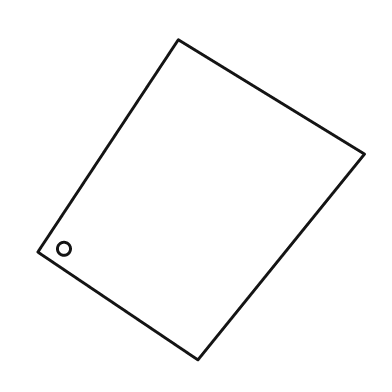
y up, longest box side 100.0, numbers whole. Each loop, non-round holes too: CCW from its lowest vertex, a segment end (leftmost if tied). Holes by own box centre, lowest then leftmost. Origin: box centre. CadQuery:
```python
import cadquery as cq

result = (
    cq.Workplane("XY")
    .moveTo(-1.0, -49.0)
    .lineTo(50.0, 14.0)
    .lineTo(-7.0, 49.0)
    .lineTo(-50.0, -16.0)
    .close()
    .moveTo(-42.0, -15.0)
    .circle(2.0)
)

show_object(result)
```